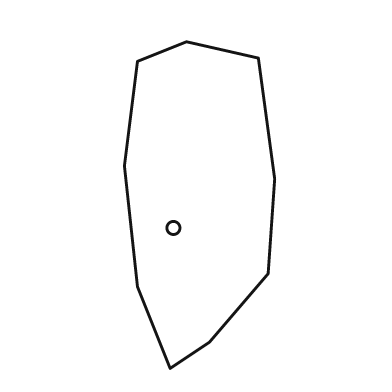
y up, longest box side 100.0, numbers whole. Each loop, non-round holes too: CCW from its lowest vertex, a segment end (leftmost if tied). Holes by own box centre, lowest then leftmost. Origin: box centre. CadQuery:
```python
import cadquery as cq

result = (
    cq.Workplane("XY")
    .moveTo(-9.0, -50.0)
    .lineTo(3.0, -42.0)
    .lineTo(21.0, -21.0)
    .lineTo(23.0, 8.0)
    .lineTo(18.0, 45.0)
    .lineTo(-4.0, 50.0)
    .lineTo(-19.0, 44.0)
    .lineTo(-23.0, 12.0)
    .lineTo(-19.0, -25.0)
    .close()
    .moveTo(-8.0, -7.0)
    .circle(2.0)
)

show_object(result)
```